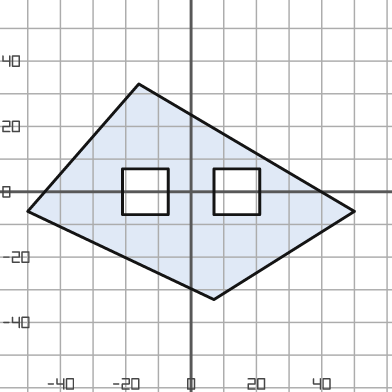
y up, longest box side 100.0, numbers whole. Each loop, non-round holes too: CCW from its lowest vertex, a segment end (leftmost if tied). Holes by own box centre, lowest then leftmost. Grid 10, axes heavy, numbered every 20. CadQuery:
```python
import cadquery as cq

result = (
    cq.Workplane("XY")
    .moveTo(7.0, -33.0)
    .lineTo(50.0, -6.0)
    .lineTo(-16.0, 33.0)
    .lineTo(-50.0, -6.0)
    .close()
    .moveTo(-21.0, -7.0)
    .lineTo(-7.0, -7.0)
    .lineTo(-7.0, 7.0)
    .lineTo(-21.0, 7.0)
    .close()
    .moveTo(7.0, -7.0)
    .lineTo(21.0, -7.0)
    .lineTo(21.0, 7.0)
    .lineTo(7.0, 7.0)
    .close()
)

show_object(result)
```